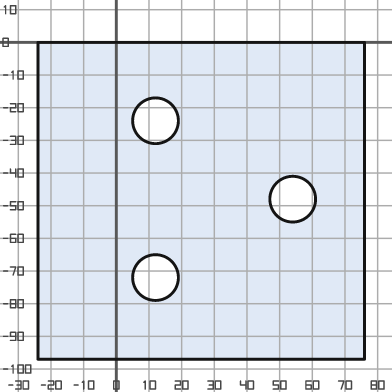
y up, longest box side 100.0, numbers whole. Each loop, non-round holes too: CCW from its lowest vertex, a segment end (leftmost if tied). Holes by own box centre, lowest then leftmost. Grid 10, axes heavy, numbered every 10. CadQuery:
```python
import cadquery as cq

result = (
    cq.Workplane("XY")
    .moveTo(-24.0, -97.0)
    .lineTo(76.0, -97.0)
    .lineTo(76.0, 0.0)
    .lineTo(-24.0, 0.0)
    .close()
    .moveTo(12.0, -72.0)
    .circle(7.0)
    .moveTo(54.0, -48.0)
    .circle(7.0)
    .moveTo(12.0, -24.0)
    .circle(7.0)
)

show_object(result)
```